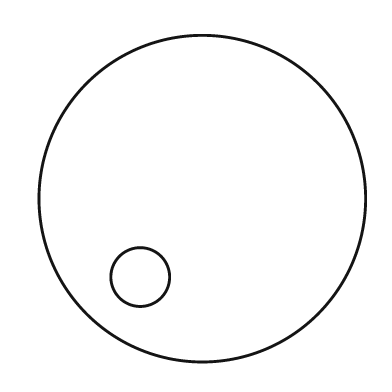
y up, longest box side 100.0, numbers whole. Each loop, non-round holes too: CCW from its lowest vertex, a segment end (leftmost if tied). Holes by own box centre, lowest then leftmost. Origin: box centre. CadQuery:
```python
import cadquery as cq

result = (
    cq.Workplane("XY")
    .moveTo(0.0, 0.0)
    .circle(50.0)
    .moveTo(-19.0, -24.0)
    .circle(9.0)
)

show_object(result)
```